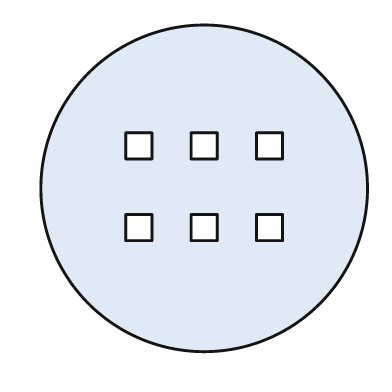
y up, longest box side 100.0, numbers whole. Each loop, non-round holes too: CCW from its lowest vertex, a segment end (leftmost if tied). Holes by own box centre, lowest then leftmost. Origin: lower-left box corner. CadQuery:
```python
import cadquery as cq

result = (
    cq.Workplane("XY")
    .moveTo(50.0, 50.0)
    .circle(50.0)
    .moveTo(26.0, 34.0)
    .lineTo(34.0, 34.0)
    .lineTo(34.0, 42.0)
    .lineTo(26.0, 42.0)
    .close()
    .moveTo(46.0, 34.0)
    .lineTo(54.0, 34.0)
    .lineTo(54.0, 42.0)
    .lineTo(46.0, 42.0)
    .close()
    .moveTo(66.0, 34.0)
    .lineTo(74.0, 34.0)
    .lineTo(74.0, 42.0)
    .lineTo(66.0, 42.0)
    .close()
    .moveTo(26.0, 59.0)
    .lineTo(34.0, 59.0)
    .lineTo(34.0, 67.0)
    .lineTo(26.0, 67.0)
    .close()
    .moveTo(46.0, 59.0)
    .lineTo(54.0, 59.0)
    .lineTo(54.0, 67.0)
    .lineTo(46.0, 67.0)
    .close()
    .moveTo(66.0, 59.0)
    .lineTo(74.0, 59.0)
    .lineTo(74.0, 67.0)
    .lineTo(66.0, 67.0)
    .close()
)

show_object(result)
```